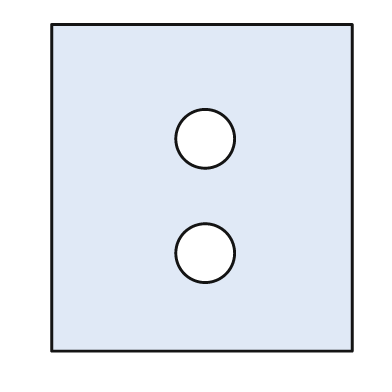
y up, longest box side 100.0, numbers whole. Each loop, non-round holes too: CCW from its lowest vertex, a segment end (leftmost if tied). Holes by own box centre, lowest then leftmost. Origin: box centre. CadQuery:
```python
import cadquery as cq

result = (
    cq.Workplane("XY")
    .moveTo(-46.0, -50.0)
    .lineTo(46.0, -50.0)
    .lineTo(46.0, 50.0)
    .lineTo(-46.0, 50.0)
    .close()
    .moveTo(1.0, -20.0)
    .circle(9.0)
    .moveTo(1.0, 15.0)
    .circle(9.0)
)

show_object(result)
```